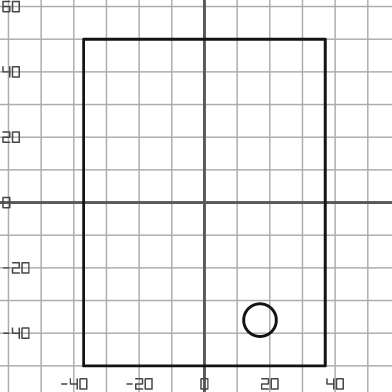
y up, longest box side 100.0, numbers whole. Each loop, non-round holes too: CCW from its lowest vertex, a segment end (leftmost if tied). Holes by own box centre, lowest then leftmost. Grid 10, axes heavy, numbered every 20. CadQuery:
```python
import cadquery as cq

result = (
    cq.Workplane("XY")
    .moveTo(-37.0, -50.0)
    .lineTo(37.0, -50.0)
    .lineTo(37.0, 50.0)
    .lineTo(-37.0, 50.0)
    .close()
    .moveTo(17.0, -36.0)
    .circle(5.0)
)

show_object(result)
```